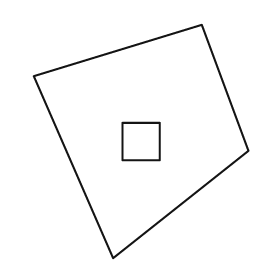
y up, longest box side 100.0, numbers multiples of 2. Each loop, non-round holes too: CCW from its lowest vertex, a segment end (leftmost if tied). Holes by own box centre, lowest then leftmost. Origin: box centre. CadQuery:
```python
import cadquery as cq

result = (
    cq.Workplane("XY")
    .moveTo(-12.0, -50.0)
    .lineTo(46.0, -4.0)
    .lineTo(26.0, 50.0)
    .lineTo(-46.0, 28.0)
    .close()
    .moveTo(-8.0, -8.0)
    .lineTo(8.0, -8.0)
    .lineTo(8.0, 8.0)
    .lineTo(-8.0, 8.0)
    .close()
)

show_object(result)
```